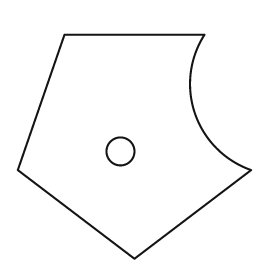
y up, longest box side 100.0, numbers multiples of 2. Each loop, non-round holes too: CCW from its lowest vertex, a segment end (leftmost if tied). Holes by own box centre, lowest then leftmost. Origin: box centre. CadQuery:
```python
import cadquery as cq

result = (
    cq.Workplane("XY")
    .moveTo(0.0, -48.0)
    .lineTo(50.0, -10.0)
    .threePointArc((26.0, 14.0), (30.0, 48.0))
    .lineTo(-30.0, 48.0)
    .lineTo(-50.0, -10.0)
    .close()
    .moveTo(-6.0, -2.0)
    .circle(6.0)
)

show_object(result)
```